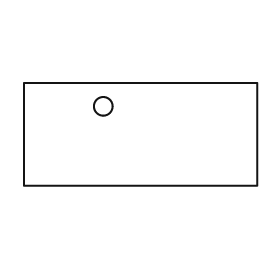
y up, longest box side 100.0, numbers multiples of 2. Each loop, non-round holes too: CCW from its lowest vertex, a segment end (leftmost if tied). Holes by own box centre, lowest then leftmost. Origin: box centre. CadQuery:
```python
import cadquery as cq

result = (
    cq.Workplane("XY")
    .moveTo(-50.0, -22.0)
    .lineTo(50.0, -22.0)
    .lineTo(50.0, 22.0)
    .lineTo(-50.0, 22.0)
    .close()
    .moveTo(-16.0, 12.0)
    .circle(4.0)
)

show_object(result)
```